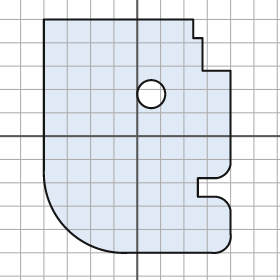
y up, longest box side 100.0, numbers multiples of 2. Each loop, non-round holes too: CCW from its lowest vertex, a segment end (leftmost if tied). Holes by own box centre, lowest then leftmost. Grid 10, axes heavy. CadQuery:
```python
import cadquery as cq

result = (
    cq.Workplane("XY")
    .moveTo(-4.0, -50.0)
    .lineTo(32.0, -50.0)
    .threePointArc((38.0, -48.0), (40.0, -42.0))
    .lineTo(40.0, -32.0)
    .threePointArc((38.0, -28.0), (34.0, -26.0))
    .lineTo(26.0, -26.0)
    .lineTo(26.0, -18.0)
    .lineTo(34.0, -18.0)
    .threePointArc((38.0, -16.0), (40.0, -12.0))
    .lineTo(40.0, 28.0)
    .lineTo(28.0, 28.0)
    .lineTo(28.0, 42.0)
    .lineTo(24.0, 42.0)
    .lineTo(24.0, 50.0)
    .lineTo(-40.0, 50.0)
    .lineTo(-40.0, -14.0)
    .threePointArc((-30.0, -40.0), (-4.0, -50.0))
    .close()
    .moveTo(6.0, 18.0)
    .circle(6.0)
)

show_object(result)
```